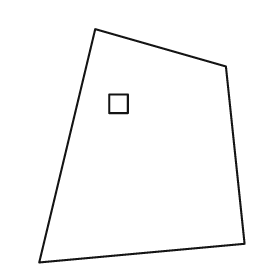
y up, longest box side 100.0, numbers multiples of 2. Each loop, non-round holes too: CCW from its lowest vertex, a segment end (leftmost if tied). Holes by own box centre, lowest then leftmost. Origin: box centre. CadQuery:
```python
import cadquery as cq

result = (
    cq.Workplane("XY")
    .moveTo(-44.0, -50.0)
    .lineTo(44.0, -42.0)
    .lineTo(36.0, 34.0)
    .lineTo(-20.0, 50.0)
    .close()
    .moveTo(-14.0, 14.0)
    .lineTo(-6.0, 14.0)
    .lineTo(-6.0, 22.0)
    .lineTo(-14.0, 22.0)
    .close()
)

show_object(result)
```